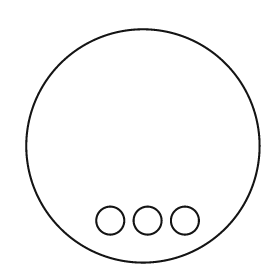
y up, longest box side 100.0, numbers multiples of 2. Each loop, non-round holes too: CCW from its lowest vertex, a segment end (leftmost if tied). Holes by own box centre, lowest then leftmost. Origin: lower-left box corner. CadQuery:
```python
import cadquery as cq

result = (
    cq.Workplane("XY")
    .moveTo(50.0, 50.0)
    .circle(50.0)
    .moveTo(36.0, 18.0)
    .circle(6.0)
    .moveTo(52.0, 18.0)
    .circle(6.0)
    .moveTo(68.0, 18.0)
    .circle(6.0)
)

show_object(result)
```